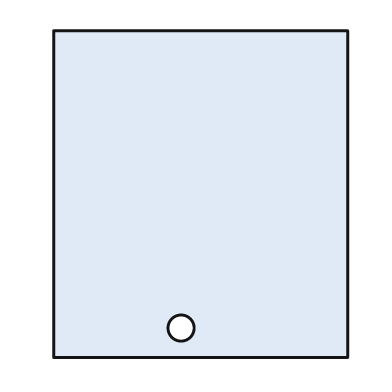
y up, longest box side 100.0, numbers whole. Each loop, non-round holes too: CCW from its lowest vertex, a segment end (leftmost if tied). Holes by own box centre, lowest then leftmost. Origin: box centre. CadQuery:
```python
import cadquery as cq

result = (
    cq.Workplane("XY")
    .moveTo(-45.0, -50.0)
    .lineTo(45.0, -50.0)
    .lineTo(45.0, 50.0)
    .lineTo(-45.0, 50.0)
    .close()
    .moveTo(-6.0, -41.0)
    .circle(4.0)
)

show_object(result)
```